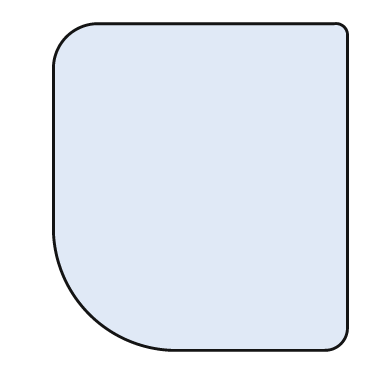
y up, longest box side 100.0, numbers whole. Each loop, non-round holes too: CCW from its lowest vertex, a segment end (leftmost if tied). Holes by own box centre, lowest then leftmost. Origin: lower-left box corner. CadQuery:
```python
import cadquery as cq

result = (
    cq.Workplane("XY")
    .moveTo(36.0, 0.0)
    .lineTo(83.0, 0.0)
    .threePointArc((88.0, 2.0), (90.0, 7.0))
    .lineTo(90.0, 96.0)
    .threePointArc((89.0, 99.0), (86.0, 100.0))
    .lineTo(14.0, 100.0)
    .threePointArc((4.0, 96.0), (0.0, 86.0))
    .lineTo(0.0, 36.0)
    .threePointArc((11.0, 11.0), (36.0, 0.0))
    .close()
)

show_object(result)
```